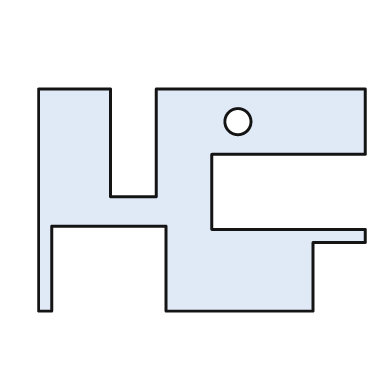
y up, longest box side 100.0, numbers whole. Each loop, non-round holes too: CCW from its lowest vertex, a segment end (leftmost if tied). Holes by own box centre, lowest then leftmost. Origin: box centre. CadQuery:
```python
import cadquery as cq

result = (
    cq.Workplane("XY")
    .moveTo(-50.0, -34.0)
    .lineTo(-46.0, -34.0)
    .lineTo(-46.0, -8.0)
    .lineTo(-11.0, -8.0)
    .lineTo(-11.0, -34.0)
    .lineTo(34.0, -34.0)
    .lineTo(34.0, -13.0)
    .lineTo(50.0, -13.0)
    .lineTo(50.0, -9.0)
    .lineTo(3.0, -9.0)
    .lineTo(3.0, 14.0)
    .lineTo(50.0, 14.0)
    .lineTo(50.0, 34.0)
    .lineTo(-14.0, 34.0)
    .lineTo(-14.0, 1.0)
    .lineTo(-28.0, 1.0)
    .lineTo(-28.0, 34.0)
    .lineTo(-50.0, 34.0)
    .close()
    .moveTo(11.0, 24.0)
    .circle(4.0)
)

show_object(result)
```